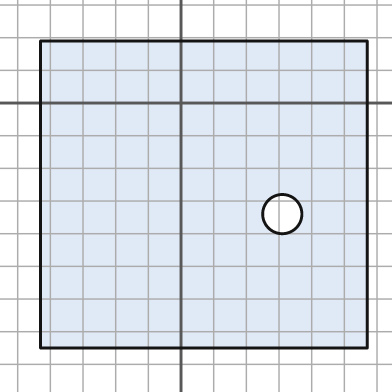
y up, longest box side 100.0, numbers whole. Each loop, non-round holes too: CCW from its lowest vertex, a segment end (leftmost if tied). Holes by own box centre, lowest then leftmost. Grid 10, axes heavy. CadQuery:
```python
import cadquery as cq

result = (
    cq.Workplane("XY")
    .moveTo(-43.0, -75.0)
    .lineTo(57.0, -75.0)
    .lineTo(57.0, 19.0)
    .lineTo(-43.0, 19.0)
    .close()
    .moveTo(31.0, -34.0)
    .circle(6.0)
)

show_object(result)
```